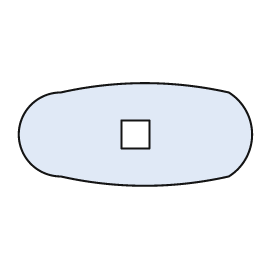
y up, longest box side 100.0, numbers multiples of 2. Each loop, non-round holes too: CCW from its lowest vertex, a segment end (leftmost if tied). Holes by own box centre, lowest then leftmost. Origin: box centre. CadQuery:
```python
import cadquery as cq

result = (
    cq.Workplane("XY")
    .moveTo(-32.0, -18.0)
    .threePointArc((4.0, -22.0), (40.0, -18.0))
    .threePointArc((50.0, 0.0), (40.0, 18.0))
    .threePointArc((4.0, 22.0), (-32.0, 18.0))
    .threePointArc((-50.0, 0.0), (-32.0, -18.0))
    .close()
    .moveTo(-6.0, -6.0)
    .lineTo(6.0, -6.0)
    .lineTo(6.0, 6.0)
    .lineTo(-6.0, 6.0)
    .close()
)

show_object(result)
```